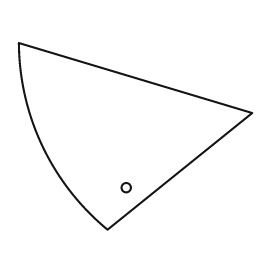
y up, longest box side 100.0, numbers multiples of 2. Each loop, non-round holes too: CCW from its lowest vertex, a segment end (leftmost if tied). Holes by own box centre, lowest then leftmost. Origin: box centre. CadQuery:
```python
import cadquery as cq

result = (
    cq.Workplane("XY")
    .moveTo(-12.0, -40.0)
    .lineTo(50.0, 10.0)
    .lineTo(-50.0, 40.0)
    .threePointArc((-40.0, -4.0), (-12.0, -40.0))
    .close()
    .moveTo(-4.0, -22.0)
    .circle(2.0)
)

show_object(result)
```